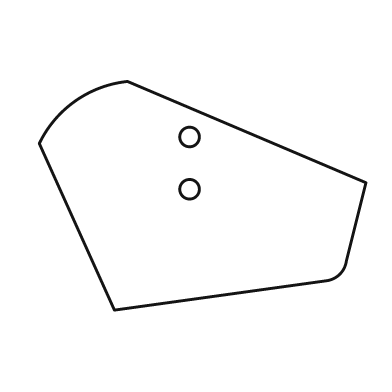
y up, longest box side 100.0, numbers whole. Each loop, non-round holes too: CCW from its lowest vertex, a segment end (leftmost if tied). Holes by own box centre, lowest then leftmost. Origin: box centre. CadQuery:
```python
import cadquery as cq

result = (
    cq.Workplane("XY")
    .moveTo(-27.0, -35.0)
    .lineTo(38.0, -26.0)
    .threePointArc((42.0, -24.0), (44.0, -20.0))
    .lineTo(50.0, 4.0)
    .lineTo(-23.0, 35.0)
    .threePointArc((-39.0, 29.0), (-50.0, 16.0))
    .close()
    .moveTo(-4.0, 2.0)
    .circle(3.0)
    .moveTo(-4.0, 18.0)
    .circle(3.0)
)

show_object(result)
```